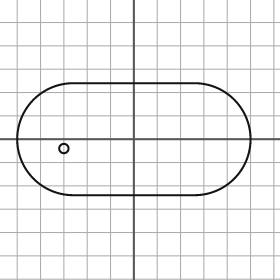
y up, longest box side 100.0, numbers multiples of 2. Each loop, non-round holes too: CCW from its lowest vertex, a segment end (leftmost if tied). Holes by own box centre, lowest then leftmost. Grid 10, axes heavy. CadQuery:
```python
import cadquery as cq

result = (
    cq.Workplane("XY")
    .moveTo(-26.0, -24.0)
    .lineTo(26.0, -24.0)
    .threePointArc((50.0, 0.0), (26.0, 24.0))
    .lineTo(-26.0, 24.0)
    .threePointArc((-50.0, 0.0), (-26.0, -24.0))
    .close()
    .moveTo(-30.0, -4.0)
    .circle(2.0)
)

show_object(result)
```